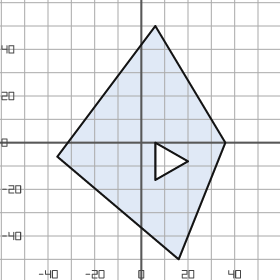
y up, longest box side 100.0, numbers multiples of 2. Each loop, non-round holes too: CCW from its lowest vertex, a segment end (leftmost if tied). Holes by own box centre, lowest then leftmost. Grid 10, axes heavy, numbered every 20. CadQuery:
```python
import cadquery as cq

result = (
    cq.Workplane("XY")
    .moveTo(16.0, -50.0)
    .lineTo(36.0, 0.0)
    .lineTo(6.0, 50.0)
    .lineTo(-36.0, -6.0)
    .close()
    .moveTo(6.0, -16.0)
    .lineTo(20.0, -8.0)
    .lineTo(6.0, 0.0)
    .close()
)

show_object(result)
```